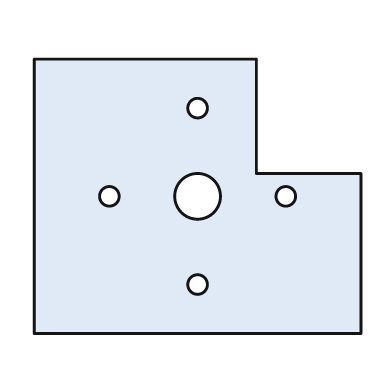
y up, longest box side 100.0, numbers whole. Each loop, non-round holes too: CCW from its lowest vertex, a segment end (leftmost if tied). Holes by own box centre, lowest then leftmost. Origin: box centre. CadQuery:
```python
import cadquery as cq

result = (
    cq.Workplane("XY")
    .moveTo(-50.0, -42.0)
    .lineTo(50.0, -42.0)
    .lineTo(50.0, 7.0)
    .lineTo(18.0, 7.0)
    .lineTo(18.0, 42.0)
    .lineTo(-50.0, 42.0)
    .close()
    .moveTo(0.0, -27.0)
    .circle(3.0)
    .moveTo(-27.0, 0.0)
    .circle(3.0)
    .moveTo(0.0, 0.0)
    .circle(7.0)
    .moveTo(27.0, 0.0)
    .circle(3.0)
    .moveTo(0.0, 27.0)
    .circle(3.0)
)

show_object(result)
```